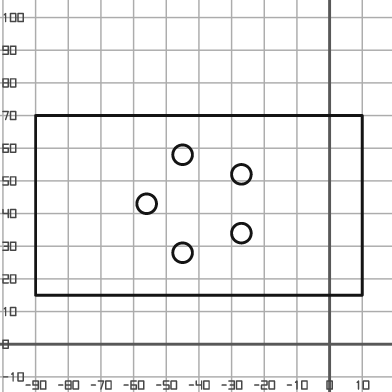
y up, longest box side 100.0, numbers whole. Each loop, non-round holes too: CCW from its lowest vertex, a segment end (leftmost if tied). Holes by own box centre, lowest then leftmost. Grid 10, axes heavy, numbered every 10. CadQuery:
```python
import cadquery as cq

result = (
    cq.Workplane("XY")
    .moveTo(-90.0, 15.0)
    .lineTo(10.0, 15.0)
    .lineTo(10.0, 70.0)
    .lineTo(-90.0, 70.0)
    .close()
    .moveTo(-45.0, 28.0)
    .circle(3.0)
    .moveTo(-27.0, 34.0)
    .circle(3.0)
    .moveTo(-56.0, 43.0)
    .circle(3.0)
    .moveTo(-27.0, 52.0)
    .circle(3.0)
    .moveTo(-45.0, 58.0)
    .circle(3.0)
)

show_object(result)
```